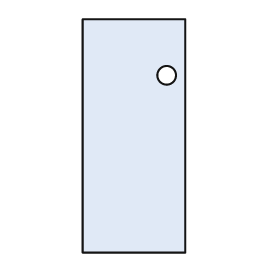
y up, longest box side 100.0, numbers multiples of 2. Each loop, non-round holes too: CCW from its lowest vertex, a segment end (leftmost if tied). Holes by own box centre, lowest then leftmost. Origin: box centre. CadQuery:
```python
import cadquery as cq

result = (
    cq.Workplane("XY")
    .moveTo(-22.0, -50.0)
    .lineTo(22.0, -50.0)
    .lineTo(22.0, 50.0)
    .lineTo(-22.0, 50.0)
    .close()
    .moveTo(14.0, 26.0)
    .circle(4.0)
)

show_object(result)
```